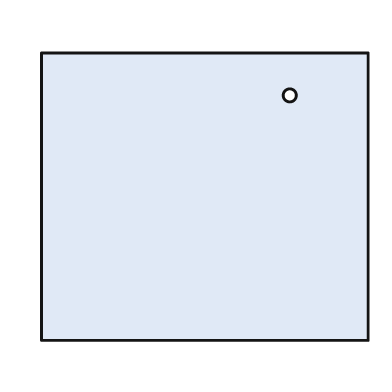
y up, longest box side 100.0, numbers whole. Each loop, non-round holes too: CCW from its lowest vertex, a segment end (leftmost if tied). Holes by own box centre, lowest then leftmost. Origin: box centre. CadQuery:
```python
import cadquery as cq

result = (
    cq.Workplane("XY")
    .moveTo(-50.0, -44.0)
    .lineTo(50.0, -44.0)
    .lineTo(50.0, 44.0)
    .lineTo(-50.0, 44.0)
    .close()
    .moveTo(26.0, 31.0)
    .circle(2.0)
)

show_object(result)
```